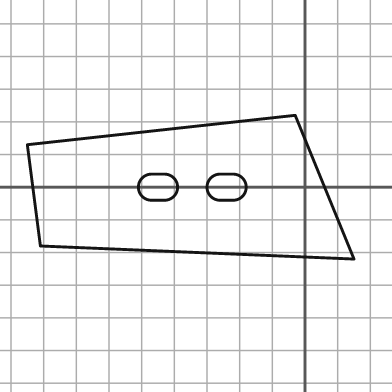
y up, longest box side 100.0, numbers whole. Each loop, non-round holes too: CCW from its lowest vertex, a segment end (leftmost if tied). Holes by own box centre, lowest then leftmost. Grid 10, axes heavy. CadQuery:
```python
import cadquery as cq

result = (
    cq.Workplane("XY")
    .moveTo(15.0, -22.0)
    .lineTo(-3.0, 22.0)
    .lineTo(-85.0, 13.0)
    .lineTo(-81.0, -18.0)
    .close()
    .moveTo(-47.0, -4.0)
    .lineTo(-43.0, -4.0)
    .threePointArc((-39.0, 0.0), (-43.0, 4.0))
    .lineTo(-47.0, 4.0)
    .threePointArc((-51.0, 0.0), (-47.0, -4.0))
    .close()
    .moveTo(-26.0, -4.0)
    .lineTo(-22.0, -4.0)
    .threePointArc((-18.0, 0.0), (-22.0, 4.0))
    .lineTo(-26.0, 4.0)
    .threePointArc((-30.0, 0.0), (-26.0, -4.0))
    .close()
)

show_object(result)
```